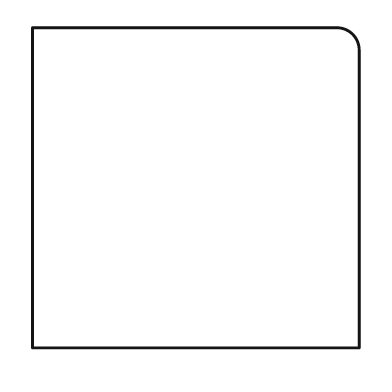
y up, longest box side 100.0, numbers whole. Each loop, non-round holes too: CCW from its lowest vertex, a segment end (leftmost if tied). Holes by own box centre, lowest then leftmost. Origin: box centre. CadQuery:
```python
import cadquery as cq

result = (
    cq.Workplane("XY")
    .moveTo(-50.0, -49.0)
    .lineTo(50.0, -49.0)
    .lineTo(50.0, 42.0)
    .threePointArc((48.0, 47.0), (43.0, 49.0))
    .lineTo(-50.0, 49.0)
    .close()
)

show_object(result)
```